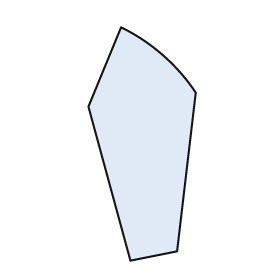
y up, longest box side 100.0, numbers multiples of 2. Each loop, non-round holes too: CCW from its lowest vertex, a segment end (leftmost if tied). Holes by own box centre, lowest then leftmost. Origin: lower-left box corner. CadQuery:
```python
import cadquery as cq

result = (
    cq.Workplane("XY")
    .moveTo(18.0, 0.0)
    .lineTo(38.0, 4.0)
    .lineTo(46.0, 72.0)
    .threePointArc((32.0, 88.0), (14.0, 100.0))
    .lineTo(0.0, 66.0)
    .close()
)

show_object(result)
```